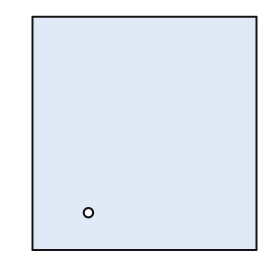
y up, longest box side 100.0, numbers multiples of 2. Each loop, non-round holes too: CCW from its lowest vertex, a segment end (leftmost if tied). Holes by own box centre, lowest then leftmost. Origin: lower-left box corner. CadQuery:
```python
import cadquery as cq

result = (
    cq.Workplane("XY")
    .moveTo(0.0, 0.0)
    .lineTo(96.0, 0.0)
    .lineTo(96.0, 100.0)
    .lineTo(0.0, 100.0)
    .close()
    .moveTo(24.0, 16.0)
    .circle(2.0)
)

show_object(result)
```